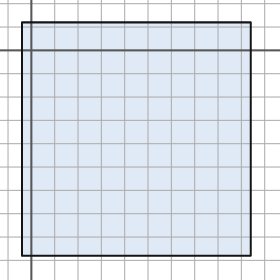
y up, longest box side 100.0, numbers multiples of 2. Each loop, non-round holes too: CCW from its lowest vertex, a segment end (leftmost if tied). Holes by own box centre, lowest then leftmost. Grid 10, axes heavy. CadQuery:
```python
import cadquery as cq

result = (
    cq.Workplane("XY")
    .moveTo(-4.0, -88.0)
    .lineTo(94.0, -88.0)
    .lineTo(94.0, 12.0)
    .lineTo(-4.0, 12.0)
    .close()
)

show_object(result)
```